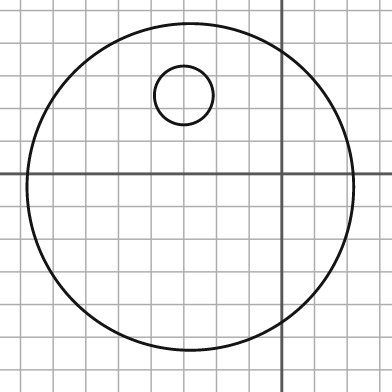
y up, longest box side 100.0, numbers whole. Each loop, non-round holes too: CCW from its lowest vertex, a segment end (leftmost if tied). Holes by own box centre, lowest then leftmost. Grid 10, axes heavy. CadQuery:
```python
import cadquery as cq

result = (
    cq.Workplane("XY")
    .moveTo(-28.0, -4.0)
    .circle(50.0)
    .moveTo(-30.0, 24.0)
    .circle(9.0)
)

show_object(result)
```